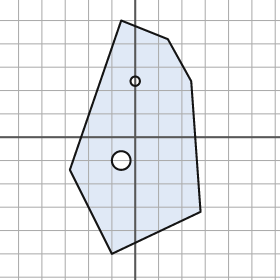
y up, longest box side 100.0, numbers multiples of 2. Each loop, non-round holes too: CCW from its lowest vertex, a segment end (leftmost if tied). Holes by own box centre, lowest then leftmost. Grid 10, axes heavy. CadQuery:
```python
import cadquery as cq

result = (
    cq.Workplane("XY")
    .moveTo(-10.0, -50.0)
    .lineTo(28.0, -32.0)
    .lineTo(24.0, 24.0)
    .lineTo(14.0, 42.0)
    .lineTo(-6.0, 50.0)
    .lineTo(-28.0, -14.0)
    .close()
    .moveTo(-6.0, -10.0)
    .circle(4.0)
    .moveTo(0.0, 24.0)
    .circle(2.0)
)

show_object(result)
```